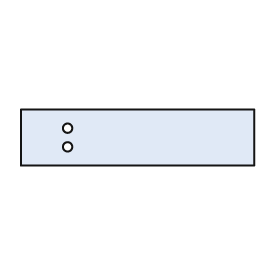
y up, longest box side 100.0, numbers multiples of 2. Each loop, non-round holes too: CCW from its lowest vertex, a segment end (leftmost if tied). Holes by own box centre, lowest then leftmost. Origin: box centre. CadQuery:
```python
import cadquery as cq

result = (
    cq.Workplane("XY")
    .moveTo(-50.0, -12.0)
    .lineTo(50.0, -12.0)
    .lineTo(50.0, 12.0)
    .lineTo(-50.0, 12.0)
    .close()
    .moveTo(-30.0, -4.0)
    .circle(2.0)
    .moveTo(-30.0, 4.0)
    .circle(2.0)
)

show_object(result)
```